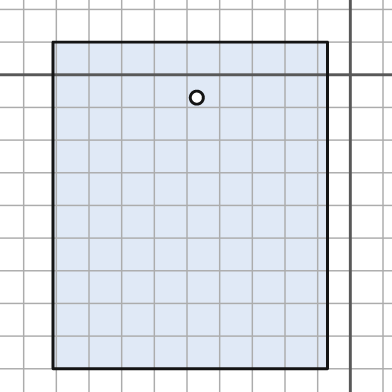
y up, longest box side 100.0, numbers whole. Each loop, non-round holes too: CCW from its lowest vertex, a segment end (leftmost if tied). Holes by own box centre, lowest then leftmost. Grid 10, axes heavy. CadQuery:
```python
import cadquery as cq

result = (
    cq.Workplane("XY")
    .moveTo(-91.0, -90.0)
    .lineTo(-7.0, -90.0)
    .lineTo(-7.0, 10.0)
    .lineTo(-91.0, 10.0)
    .close()
    .moveTo(-47.0, -7.0)
    .circle(2.0)
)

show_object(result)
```